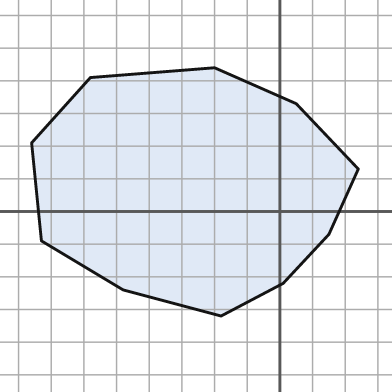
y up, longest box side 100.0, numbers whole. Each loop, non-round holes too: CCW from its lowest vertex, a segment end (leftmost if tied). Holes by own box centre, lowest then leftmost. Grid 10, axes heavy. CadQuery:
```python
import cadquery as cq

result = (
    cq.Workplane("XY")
    .moveTo(-18.0, -32.0)
    .lineTo(1.0, -22.0)
    .lineTo(15.0, -7.0)
    .lineTo(24.0, 13.0)
    .lineTo(5.0, 33.0)
    .lineTo(-20.0, 44.0)
    .lineTo(-58.0, 41.0)
    .lineTo(-76.0, 21.0)
    .lineTo(-73.0, -9.0)
    .lineTo(-48.0, -24.0)
    .close()
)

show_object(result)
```